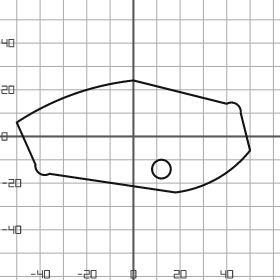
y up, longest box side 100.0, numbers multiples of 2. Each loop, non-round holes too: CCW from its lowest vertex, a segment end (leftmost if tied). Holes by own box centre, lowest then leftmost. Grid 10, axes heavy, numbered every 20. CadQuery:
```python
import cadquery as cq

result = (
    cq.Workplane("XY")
    .moveTo(18.0, -24.0)
    .threePointArc((36.0, -18.0), (50.0, -6.0))
    .lineTo(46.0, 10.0)
    .threePointArc((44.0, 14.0), (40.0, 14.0))
    .lineTo(0.0, 24.0)
    .threePointArc((-26.0, 18.0), (-50.0, 6.0))
    .lineTo(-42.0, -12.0)
    .threePointArc((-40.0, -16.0), (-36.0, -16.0))
    .close()
    .moveTo(12.0, -14.0)
    .circle(4.0)
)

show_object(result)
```